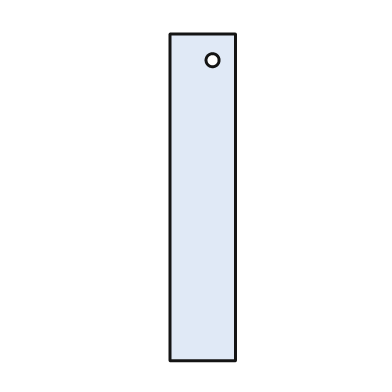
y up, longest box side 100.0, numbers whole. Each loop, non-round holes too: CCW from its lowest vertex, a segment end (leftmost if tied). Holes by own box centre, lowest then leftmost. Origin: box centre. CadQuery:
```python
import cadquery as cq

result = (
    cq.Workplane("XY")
    .moveTo(-10.0, -50.0)
    .lineTo(10.0, -50.0)
    .lineTo(10.0, 50.0)
    .lineTo(-10.0, 50.0)
    .close()
    .moveTo(3.0, 42.0)
    .circle(2.0)
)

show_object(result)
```